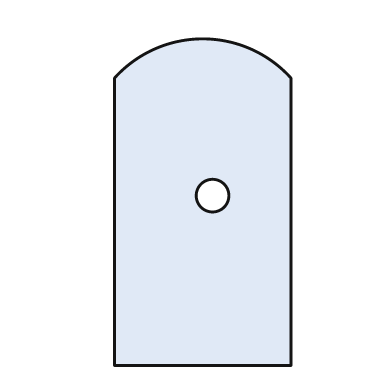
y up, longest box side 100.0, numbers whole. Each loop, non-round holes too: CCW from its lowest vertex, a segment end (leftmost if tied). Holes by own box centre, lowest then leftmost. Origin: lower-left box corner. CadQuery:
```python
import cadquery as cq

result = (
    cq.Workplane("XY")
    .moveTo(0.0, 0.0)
    .lineTo(54.0, 0.0)
    .lineTo(54.0, 88.0)
    .threePointArc((27.0, 100.0), (0.0, 88.0))
    .close()
    .moveTo(30.0, 52.0)
    .circle(5.0)
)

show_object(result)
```